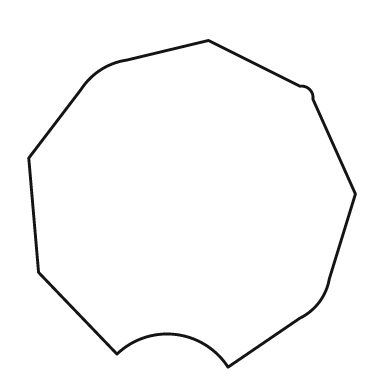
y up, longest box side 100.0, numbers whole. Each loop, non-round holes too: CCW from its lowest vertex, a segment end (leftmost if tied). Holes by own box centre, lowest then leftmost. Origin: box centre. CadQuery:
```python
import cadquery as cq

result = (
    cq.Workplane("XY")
    .moveTo(11.0, -50.0)
    .lineTo(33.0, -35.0)
    .threePointArc((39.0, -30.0), (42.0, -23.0))
    .lineTo(50.0, 3.0)
    .lineTo(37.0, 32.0)
    .threePointArc((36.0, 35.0), (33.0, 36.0))
    .lineTo(5.0, 50.0)
    .lineTo(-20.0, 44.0)
    .threePointArc((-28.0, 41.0), (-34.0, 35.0))
    .lineTo(-50.0, 14.0)
    .lineTo(-47.0, -21.0)
    .lineTo(-23.0, -46.0)
    .threePointArc((-5.0, -40.0), (11.0, -50.0))
    .close()
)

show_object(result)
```